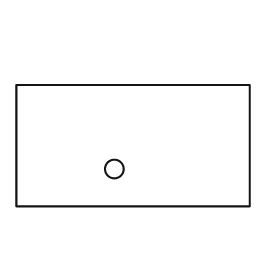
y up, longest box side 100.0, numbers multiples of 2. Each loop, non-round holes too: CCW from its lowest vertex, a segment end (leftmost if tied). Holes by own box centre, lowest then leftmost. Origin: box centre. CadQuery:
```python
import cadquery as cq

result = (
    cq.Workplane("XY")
    .moveTo(-50.0, -26.0)
    .lineTo(50.0, -26.0)
    .lineTo(50.0, 26.0)
    .lineTo(-50.0, 26.0)
    .close()
    .moveTo(-8.0, -10.0)
    .circle(4.0)
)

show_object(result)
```